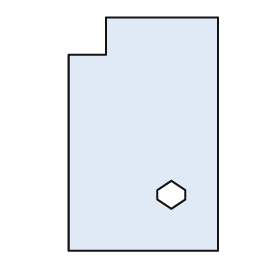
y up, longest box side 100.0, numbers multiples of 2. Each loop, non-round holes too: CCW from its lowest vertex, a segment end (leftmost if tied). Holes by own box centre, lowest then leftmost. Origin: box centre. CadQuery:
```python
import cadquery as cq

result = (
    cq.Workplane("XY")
    .moveTo(-32.0, -50.0)
    .lineTo(32.0, -50.0)
    .lineTo(32.0, 50.0)
    .lineTo(-16.0, 50.0)
    .lineTo(-16.0, 34.0)
    .lineTo(-32.0, 34.0)
    .close()
    .moveTo(12.0, -32.0)
    .lineTo(18.0, -28.0)
    .lineTo(18.0, -24.0)
    .lineTo(12.0, -20.0)
    .lineTo(6.0, -24.0)
    .lineTo(6.0, -28.0)
    .close()
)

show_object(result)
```